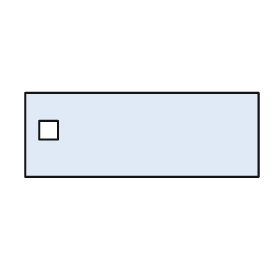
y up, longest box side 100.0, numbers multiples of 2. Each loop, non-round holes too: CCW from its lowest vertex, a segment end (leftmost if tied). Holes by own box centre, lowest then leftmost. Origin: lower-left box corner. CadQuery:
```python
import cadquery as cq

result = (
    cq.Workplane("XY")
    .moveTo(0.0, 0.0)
    .lineTo(100.0, 0.0)
    .lineTo(100.0, 36.0)
    .lineTo(0.0, 36.0)
    .close()
    .moveTo(6.0, 16.0)
    .lineTo(14.0, 16.0)
    .lineTo(14.0, 24.0)
    .lineTo(6.0, 24.0)
    .close()
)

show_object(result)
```